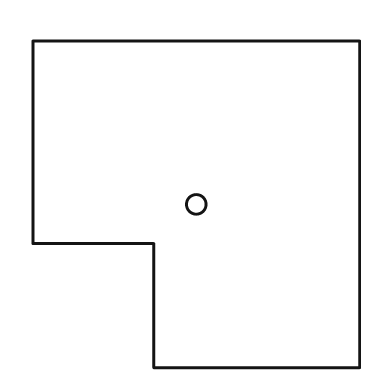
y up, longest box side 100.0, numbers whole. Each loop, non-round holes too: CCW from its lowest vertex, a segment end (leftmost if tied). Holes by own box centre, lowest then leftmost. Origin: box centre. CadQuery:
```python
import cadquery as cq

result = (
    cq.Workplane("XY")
    .moveTo(-13.0, -50.0)
    .lineTo(50.0, -50.0)
    .lineTo(50.0, 50.0)
    .lineTo(-50.0, 50.0)
    .lineTo(-50.0, -12.0)
    .lineTo(-13.0, -12.0)
    .close()
    .moveTo(0.0, 0.0)
    .circle(3.0)
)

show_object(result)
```